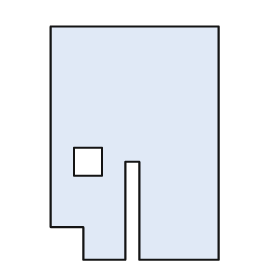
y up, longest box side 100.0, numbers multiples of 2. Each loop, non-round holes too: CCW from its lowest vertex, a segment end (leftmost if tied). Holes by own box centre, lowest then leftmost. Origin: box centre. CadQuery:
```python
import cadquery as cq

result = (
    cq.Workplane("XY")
    .moveTo(-22.0, -50.0)
    .lineTo(-4.0, -50.0)
    .lineTo(-4.0, -8.0)
    .lineTo(2.0, -8.0)
    .lineTo(2.0, -50.0)
    .lineTo(36.0, -50.0)
    .lineTo(36.0, 50.0)
    .lineTo(-36.0, 50.0)
    .lineTo(-36.0, -36.0)
    .lineTo(-22.0, -36.0)
    .close()
    .moveTo(-26.0, -14.0)
    .lineTo(-14.0, -14.0)
    .lineTo(-14.0, -2.0)
    .lineTo(-26.0, -2.0)
    .close()
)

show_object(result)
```